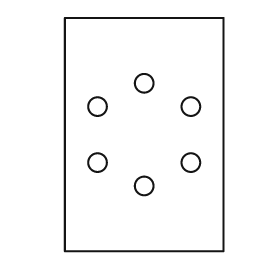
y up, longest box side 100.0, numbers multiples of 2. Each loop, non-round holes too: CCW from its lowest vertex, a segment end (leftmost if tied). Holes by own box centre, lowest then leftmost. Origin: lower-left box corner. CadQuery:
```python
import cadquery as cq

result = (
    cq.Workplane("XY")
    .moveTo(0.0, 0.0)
    .lineTo(68.0, 0.0)
    .lineTo(68.0, 100.0)
    .lineTo(0.0, 100.0)
    .close()
    .moveTo(34.0, 28.0)
    .circle(4.0)
    .moveTo(14.0, 38.0)
    .circle(4.0)
    .moveTo(54.0, 38.0)
    .circle(4.0)
    .moveTo(14.0, 62.0)
    .circle(4.0)
    .moveTo(54.0, 62.0)
    .circle(4.0)
    .moveTo(34.0, 72.0)
    .circle(4.0)
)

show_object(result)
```